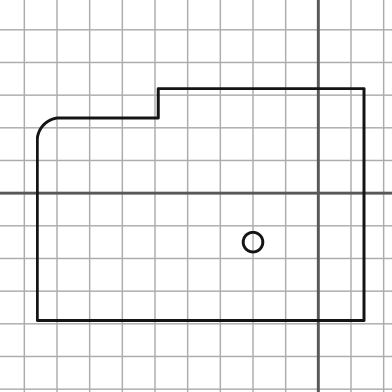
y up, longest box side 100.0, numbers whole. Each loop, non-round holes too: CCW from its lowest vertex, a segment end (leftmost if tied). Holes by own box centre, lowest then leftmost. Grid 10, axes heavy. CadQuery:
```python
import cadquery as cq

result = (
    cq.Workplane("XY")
    .moveTo(-86.0, -39.0)
    .lineTo(14.0, -39.0)
    .lineTo(14.0, 32.0)
    .lineTo(-49.0, 32.0)
    .lineTo(-49.0, 23.0)
    .lineTo(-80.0, 23.0)
    .threePointArc((-84.0, 21.0), (-86.0, 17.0))
    .close()
    .moveTo(-20.0, -15.0)
    .circle(3.0)
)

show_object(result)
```